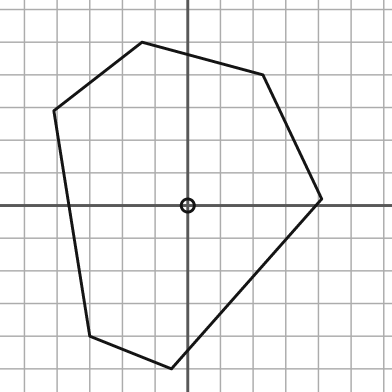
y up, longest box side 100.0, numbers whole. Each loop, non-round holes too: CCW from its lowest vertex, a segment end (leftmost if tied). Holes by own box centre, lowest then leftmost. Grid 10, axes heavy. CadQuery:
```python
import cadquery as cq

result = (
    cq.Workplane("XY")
    .moveTo(-5.0, -50.0)
    .lineTo(41.0, 2.0)
    .lineTo(23.0, 40.0)
    .lineTo(-14.0, 50.0)
    .lineTo(-41.0, 29.0)
    .lineTo(-30.0, -40.0)
    .close()
    .moveTo(0.0, 0.0)
    .circle(2.0)
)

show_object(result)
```